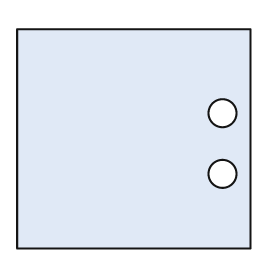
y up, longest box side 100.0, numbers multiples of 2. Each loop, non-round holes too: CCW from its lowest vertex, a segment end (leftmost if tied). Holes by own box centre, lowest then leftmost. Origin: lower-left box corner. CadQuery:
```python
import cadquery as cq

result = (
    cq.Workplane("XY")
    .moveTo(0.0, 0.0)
    .lineTo(100.0, 0.0)
    .lineTo(100.0, 94.0)
    .lineTo(0.0, 94.0)
    .close()
    .moveTo(88.0, 32.0)
    .circle(6.0)
    .moveTo(88.0, 58.0)
    .circle(6.0)
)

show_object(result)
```